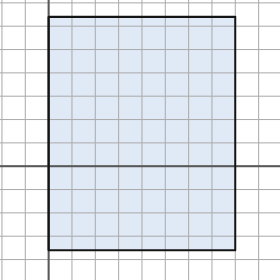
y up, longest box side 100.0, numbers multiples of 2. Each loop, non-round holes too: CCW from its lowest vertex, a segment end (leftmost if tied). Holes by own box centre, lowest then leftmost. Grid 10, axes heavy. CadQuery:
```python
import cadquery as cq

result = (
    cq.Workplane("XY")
    .moveTo(0.0, -36.0)
    .lineTo(80.0, -36.0)
    .lineTo(80.0, 64.0)
    .lineTo(0.0, 64.0)
    .close()
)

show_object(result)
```